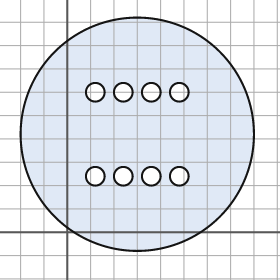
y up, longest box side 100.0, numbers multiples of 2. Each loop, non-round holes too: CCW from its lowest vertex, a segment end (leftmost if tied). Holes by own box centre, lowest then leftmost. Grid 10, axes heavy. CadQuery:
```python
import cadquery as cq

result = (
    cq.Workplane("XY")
    .moveTo(30.0, 42.0)
    .circle(50.0)
    .moveTo(12.0, 24.0)
    .circle(4.0)
    .moveTo(24.0, 24.0)
    .circle(4.0)
    .moveTo(36.0, 24.0)
    .circle(4.0)
    .moveTo(48.0, 24.0)
    .circle(4.0)
    .moveTo(12.0, 60.0)
    .circle(4.0)
    .moveTo(24.0, 60.0)
    .circle(4.0)
    .moveTo(36.0, 60.0)
    .circle(4.0)
    .moveTo(48.0, 60.0)
    .circle(4.0)
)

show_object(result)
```